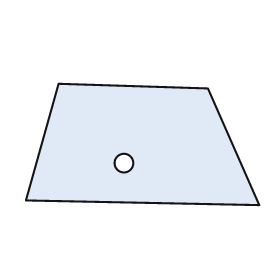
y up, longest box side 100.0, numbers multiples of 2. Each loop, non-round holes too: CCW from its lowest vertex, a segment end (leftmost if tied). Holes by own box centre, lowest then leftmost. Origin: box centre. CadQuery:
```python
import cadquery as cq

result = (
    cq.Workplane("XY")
    .moveTo(50.0, -26.0)
    .lineTo(28.0, 24.0)
    .lineTo(-36.0, 26.0)
    .lineTo(-50.0, -24.0)
    .close()
    .moveTo(-8.0, -8.0)
    .circle(4.0)
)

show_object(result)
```